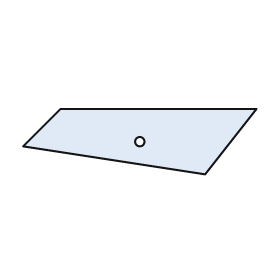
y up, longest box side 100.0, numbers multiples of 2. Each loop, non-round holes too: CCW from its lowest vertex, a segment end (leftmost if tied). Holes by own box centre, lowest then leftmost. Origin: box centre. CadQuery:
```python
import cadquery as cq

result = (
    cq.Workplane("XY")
    .moveTo(28.0, -14.0)
    .lineTo(50.0, 14.0)
    .lineTo(-34.0, 14.0)
    .lineTo(-50.0, -2.0)
    .close()
    .moveTo(0.0, 0.0)
    .circle(2.0)
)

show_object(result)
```